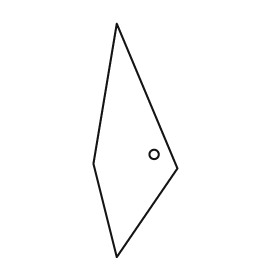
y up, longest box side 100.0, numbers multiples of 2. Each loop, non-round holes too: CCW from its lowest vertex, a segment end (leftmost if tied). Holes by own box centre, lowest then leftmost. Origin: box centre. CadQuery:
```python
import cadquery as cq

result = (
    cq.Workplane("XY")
    .moveTo(-8.0, -50.0)
    .lineTo(18.0, -12.0)
    .lineTo(-8.0, 50.0)
    .lineTo(-18.0, -10.0)
    .close()
    .moveTo(8.0, -6.0)
    .circle(2.0)
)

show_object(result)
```